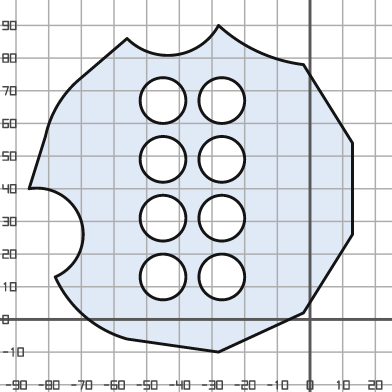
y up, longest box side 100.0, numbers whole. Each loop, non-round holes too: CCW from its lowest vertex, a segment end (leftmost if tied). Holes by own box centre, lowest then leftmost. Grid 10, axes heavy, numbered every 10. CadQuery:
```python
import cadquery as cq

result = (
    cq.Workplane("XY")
    .moveTo(-28.0, -10.0)
    .lineTo(-2.0, 2.0)
    .lineTo(13.0, 26.0)
    .lineTo(13.0, 54.0)
    .lineTo(-2.0, 78.0)
    .threePointArc((-16.0, 82.0), (-28.0, 90.0))
    .threePointArc((-41.0, 81.0), (-56.0, 86.0))
    .lineTo(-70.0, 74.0)
    .threePointArc((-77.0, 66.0), (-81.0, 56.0))
    .lineTo(-86.0, 40.0)
    .threePointArc((-70.0, 30.0), (-78.0, 13.0))
    .threePointArc((-69.0, 1.0), (-56.0, -6.0))
    .close()
    .moveTo(-45.0, 13.0)
    .circle(7.0)
    .moveTo(-27.0, 13.0)
    .circle(7.0)
    .moveTo(-45.0, 31.0)
    .circle(7.0)
    .moveTo(-27.0, 31.0)
    .circle(7.0)
    .moveTo(-45.0, 49.0)
    .circle(7.0)
    .moveTo(-27.0, 49.0)
    .circle(7.0)
    .moveTo(-45.0, 67.0)
    .circle(7.0)
    .moveTo(-27.0, 67.0)
    .circle(7.0)
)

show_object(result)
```